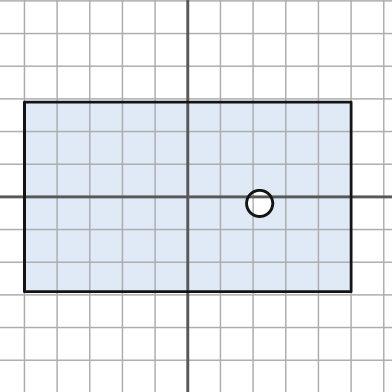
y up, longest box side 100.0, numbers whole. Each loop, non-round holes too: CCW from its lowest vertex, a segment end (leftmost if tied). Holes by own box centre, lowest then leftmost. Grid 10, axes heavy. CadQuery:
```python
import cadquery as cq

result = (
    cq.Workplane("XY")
    .moveTo(-50.0, -29.0)
    .lineTo(50.0, -29.0)
    .lineTo(50.0, 29.0)
    .lineTo(-50.0, 29.0)
    .close()
    .moveTo(22.0, -2.0)
    .circle(4.0)
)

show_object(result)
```